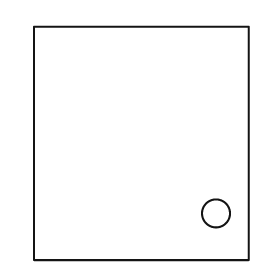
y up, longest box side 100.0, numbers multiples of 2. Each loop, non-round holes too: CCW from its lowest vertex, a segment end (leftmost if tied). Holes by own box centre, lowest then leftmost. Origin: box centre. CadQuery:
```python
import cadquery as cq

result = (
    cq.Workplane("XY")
    .moveTo(-46.0, -50.0)
    .lineTo(46.0, -50.0)
    .lineTo(46.0, 50.0)
    .lineTo(-46.0, 50.0)
    .close()
    .moveTo(32.0, -30.0)
    .circle(6.0)
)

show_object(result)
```